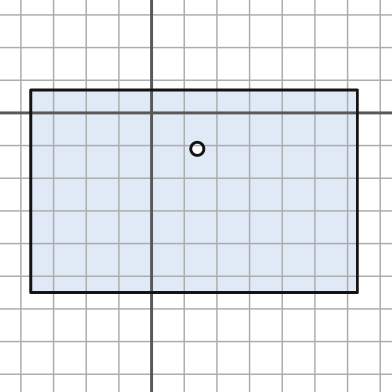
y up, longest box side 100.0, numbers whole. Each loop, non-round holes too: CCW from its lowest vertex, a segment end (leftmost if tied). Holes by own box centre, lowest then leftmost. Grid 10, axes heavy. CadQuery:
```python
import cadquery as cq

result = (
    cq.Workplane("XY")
    .moveTo(-37.0, -55.0)
    .lineTo(63.0, -55.0)
    .lineTo(63.0, 7.0)
    .lineTo(-37.0, 7.0)
    .close()
    .moveTo(14.0, -11.0)
    .circle(2.0)
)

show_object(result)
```